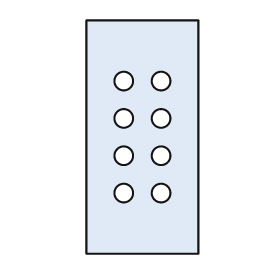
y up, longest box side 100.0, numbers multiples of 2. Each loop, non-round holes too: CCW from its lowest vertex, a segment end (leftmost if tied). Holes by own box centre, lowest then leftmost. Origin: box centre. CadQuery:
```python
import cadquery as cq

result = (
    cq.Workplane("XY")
    .moveTo(-24.0, -50.0)
    .lineTo(24.0, -50.0)
    .lineTo(24.0, 50.0)
    .lineTo(-24.0, 50.0)
    .close()
    .moveTo(-8.0, -24.0)
    .circle(4.0)
    .moveTo(8.0, -24.0)
    .circle(4.0)
    .moveTo(-8.0, -8.0)
    .circle(4.0)
    .moveTo(8.0, -8.0)
    .circle(4.0)
    .moveTo(-8.0, 8.0)
    .circle(4.0)
    .moveTo(8.0, 8.0)
    .circle(4.0)
    .moveTo(-8.0, 24.0)
    .circle(4.0)
    .moveTo(8.0, 24.0)
    .circle(4.0)
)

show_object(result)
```